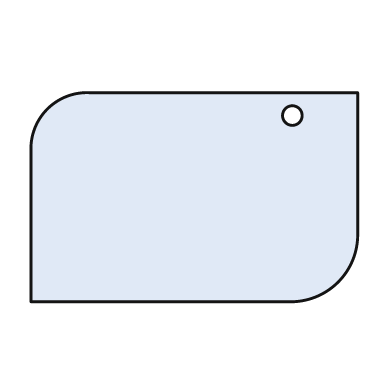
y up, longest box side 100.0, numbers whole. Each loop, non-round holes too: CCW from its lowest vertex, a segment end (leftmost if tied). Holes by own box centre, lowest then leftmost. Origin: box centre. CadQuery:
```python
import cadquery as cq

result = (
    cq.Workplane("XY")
    .moveTo(-50.0, -32.0)
    .lineTo(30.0, -32.0)
    .threePointArc((44.0, -26.0), (50.0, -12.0))
    .lineTo(50.0, 32.0)
    .lineTo(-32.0, 32.0)
    .threePointArc((-45.0, 27.0), (-50.0, 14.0))
    .close()
    .moveTo(30.0, 25.0)
    .circle(3.0)
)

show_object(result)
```